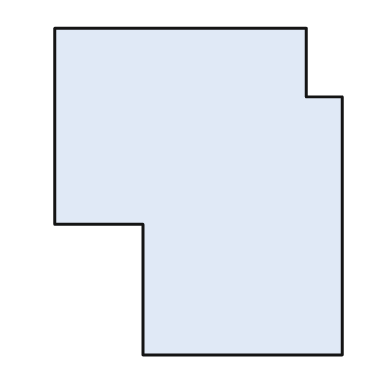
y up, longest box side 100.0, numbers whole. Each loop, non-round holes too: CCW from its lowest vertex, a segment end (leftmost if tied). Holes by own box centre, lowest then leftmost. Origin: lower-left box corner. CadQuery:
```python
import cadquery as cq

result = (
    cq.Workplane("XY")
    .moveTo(27.0, 0.0)
    .lineTo(88.0, 0.0)
    .lineTo(88.0, 79.0)
    .lineTo(77.0, 79.0)
    .lineTo(77.0, 100.0)
    .lineTo(0.0, 100.0)
    .lineTo(0.0, 40.0)
    .lineTo(27.0, 40.0)
    .close()
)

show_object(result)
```